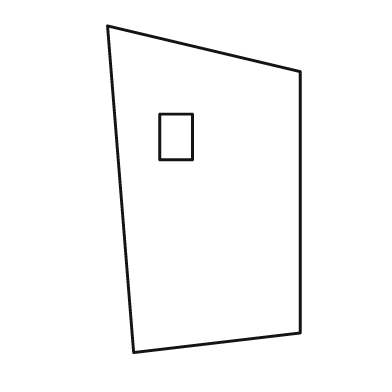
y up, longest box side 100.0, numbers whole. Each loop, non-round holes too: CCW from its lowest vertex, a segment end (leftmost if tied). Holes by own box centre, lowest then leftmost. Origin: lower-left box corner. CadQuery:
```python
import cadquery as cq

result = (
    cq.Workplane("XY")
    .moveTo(8.0, 0.0)
    .lineTo(59.0, 6.0)
    .lineTo(59.0, 86.0)
    .lineTo(0.0, 100.0)
    .close()
    .moveTo(16.0, 59.0)
    .lineTo(26.0, 59.0)
    .lineTo(26.0, 73.0)
    .lineTo(16.0, 73.0)
    .close()
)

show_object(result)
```